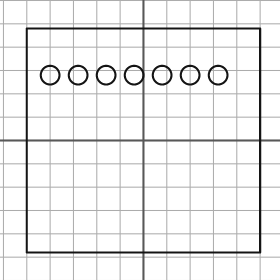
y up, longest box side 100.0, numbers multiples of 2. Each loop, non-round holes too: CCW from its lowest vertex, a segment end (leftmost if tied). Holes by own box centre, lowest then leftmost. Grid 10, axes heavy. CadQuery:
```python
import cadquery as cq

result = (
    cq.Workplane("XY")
    .moveTo(-50.0, -48.0)
    .lineTo(50.0, -48.0)
    .lineTo(50.0, 48.0)
    .lineTo(-50.0, 48.0)
    .close()
    .moveTo(-40.0, 28.0)
    .circle(4.0)
    .moveTo(-28.0, 28.0)
    .circle(4.0)
    .moveTo(-16.0, 28.0)
    .circle(4.0)
    .moveTo(-4.0, 28.0)
    .circle(4.0)
    .moveTo(8.0, 28.0)
    .circle(4.0)
    .moveTo(20.0, 28.0)
    .circle(4.0)
    .moveTo(32.0, 28.0)
    .circle(4.0)
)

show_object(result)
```